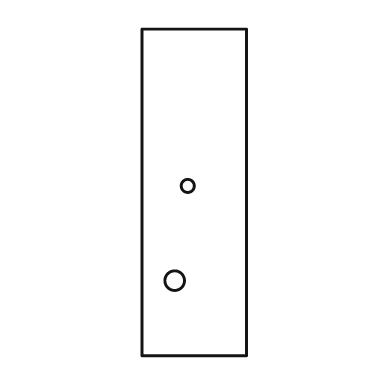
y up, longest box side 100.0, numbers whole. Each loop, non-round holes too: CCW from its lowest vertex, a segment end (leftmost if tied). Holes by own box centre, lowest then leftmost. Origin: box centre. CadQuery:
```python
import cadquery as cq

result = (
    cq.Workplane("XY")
    .moveTo(-16.0, -50.0)
    .lineTo(16.0, -50.0)
    .lineTo(16.0, 50.0)
    .lineTo(-16.0, 50.0)
    .close()
    .moveTo(-6.0, -27.0)
    .circle(3.0)
    .moveTo(-2.0, 2.0)
    .circle(2.0)
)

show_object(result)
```